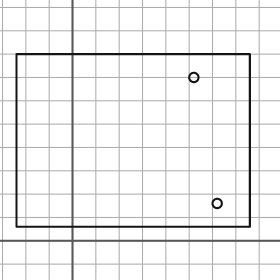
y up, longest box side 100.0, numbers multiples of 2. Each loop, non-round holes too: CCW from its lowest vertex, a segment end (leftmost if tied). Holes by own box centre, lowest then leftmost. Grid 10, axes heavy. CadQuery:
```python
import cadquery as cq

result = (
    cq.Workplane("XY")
    .moveTo(-24.0, 6.0)
    .lineTo(76.0, 6.0)
    .lineTo(76.0, 80.0)
    .lineTo(-24.0, 80.0)
    .close()
    .moveTo(62.0, 16.0)
    .circle(2.0)
    .moveTo(52.0, 70.0)
    .circle(2.0)
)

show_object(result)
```